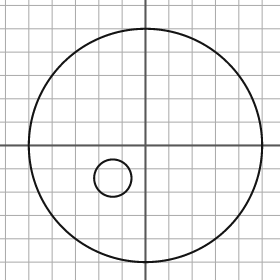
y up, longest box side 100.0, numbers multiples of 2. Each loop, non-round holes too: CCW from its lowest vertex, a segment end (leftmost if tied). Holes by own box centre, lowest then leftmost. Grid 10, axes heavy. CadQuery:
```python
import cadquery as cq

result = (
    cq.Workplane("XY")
    .moveTo(0.0, 0.0)
    .circle(50.0)
    .moveTo(-14.0, -14.0)
    .circle(8.0)
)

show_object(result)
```